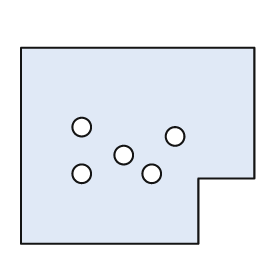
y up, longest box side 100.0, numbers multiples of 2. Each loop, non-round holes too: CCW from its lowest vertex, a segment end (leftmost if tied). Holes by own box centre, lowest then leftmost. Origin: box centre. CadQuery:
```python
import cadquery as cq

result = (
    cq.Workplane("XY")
    .moveTo(-50.0, -42.0)
    .lineTo(26.0, -42.0)
    .lineTo(26.0, -14.0)
    .lineTo(50.0, -14.0)
    .lineTo(50.0, 42.0)
    .lineTo(-50.0, 42.0)
    .close()
    .moveTo(-24.0, -12.0)
    .circle(4.0)
    .moveTo(6.0, -12.0)
    .circle(4.0)
    .moveTo(-6.0, -4.0)
    .circle(4.0)
    .moveTo(16.0, 4.0)
    .circle(4.0)
    .moveTo(-24.0, 8.0)
    .circle(4.0)
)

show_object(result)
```